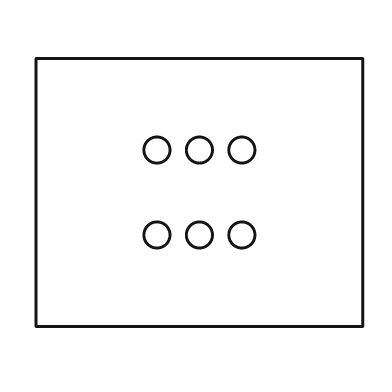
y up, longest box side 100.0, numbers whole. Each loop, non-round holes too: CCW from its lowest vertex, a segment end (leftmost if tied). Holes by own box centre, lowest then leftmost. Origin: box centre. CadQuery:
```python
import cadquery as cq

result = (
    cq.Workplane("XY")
    .moveTo(-50.0, -41.0)
    .lineTo(50.0, -41.0)
    .lineTo(50.0, 41.0)
    .lineTo(-50.0, 41.0)
    .close()
    .moveTo(-13.0, -13.0)
    .circle(4.0)
    .moveTo(0.0, -13.0)
    .circle(4.0)
    .moveTo(13.0, -13.0)
    .circle(4.0)
    .moveTo(-13.0, 13.0)
    .circle(4.0)
    .moveTo(0.0, 13.0)
    .circle(4.0)
    .moveTo(13.0, 13.0)
    .circle(4.0)
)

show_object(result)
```